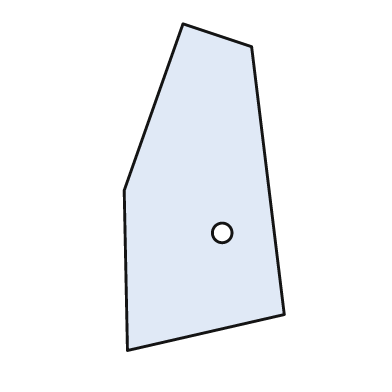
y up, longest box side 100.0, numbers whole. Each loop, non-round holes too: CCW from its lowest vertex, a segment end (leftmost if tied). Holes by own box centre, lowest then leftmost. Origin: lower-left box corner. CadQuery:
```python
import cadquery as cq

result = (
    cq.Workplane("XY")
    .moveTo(1.0, 0.0)
    .lineTo(49.0, 11.0)
    .lineTo(39.0, 93.0)
    .lineTo(18.0, 100.0)
    .lineTo(0.0, 49.0)
    .close()
    .moveTo(30.0, 36.0)
    .circle(3.0)
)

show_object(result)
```